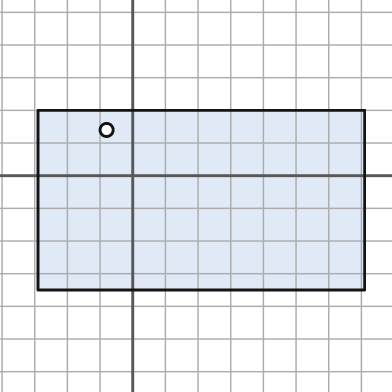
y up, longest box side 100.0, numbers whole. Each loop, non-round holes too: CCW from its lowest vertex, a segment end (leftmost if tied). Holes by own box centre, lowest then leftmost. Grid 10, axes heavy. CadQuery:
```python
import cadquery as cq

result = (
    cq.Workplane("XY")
    .moveTo(-29.0, -35.0)
    .lineTo(71.0, -35.0)
    .lineTo(71.0, 20.0)
    .lineTo(-29.0, 20.0)
    .close()
    .moveTo(-8.0, 14.0)
    .circle(2.0)
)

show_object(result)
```